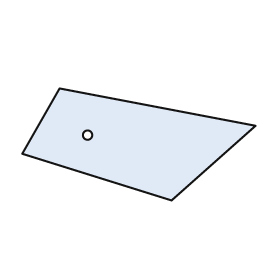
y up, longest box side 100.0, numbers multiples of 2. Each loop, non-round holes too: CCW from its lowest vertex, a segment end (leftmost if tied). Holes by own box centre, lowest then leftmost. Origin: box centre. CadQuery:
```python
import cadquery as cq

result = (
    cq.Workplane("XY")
    .moveTo(14.0, -24.0)
    .lineTo(50.0, 8.0)
    .lineTo(-34.0, 24.0)
    .lineTo(-50.0, -4.0)
    .close()
    .moveTo(-22.0, 4.0)
    .circle(2.0)
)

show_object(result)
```